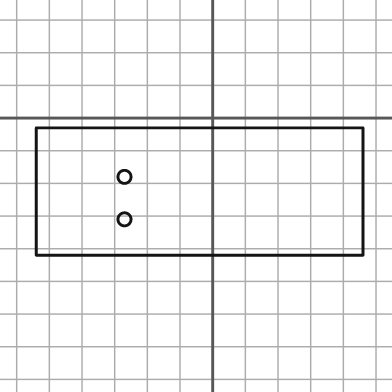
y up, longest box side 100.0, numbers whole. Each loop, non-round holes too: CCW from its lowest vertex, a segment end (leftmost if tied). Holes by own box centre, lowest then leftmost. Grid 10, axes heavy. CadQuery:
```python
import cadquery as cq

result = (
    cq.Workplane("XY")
    .moveTo(-54.0, -42.0)
    .lineTo(46.0, -42.0)
    .lineTo(46.0, -3.0)
    .lineTo(-54.0, -3.0)
    .close()
    .moveTo(-27.0, -31.0)
    .circle(2.0)
    .moveTo(-27.0, -18.0)
    .circle(2.0)
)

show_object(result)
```